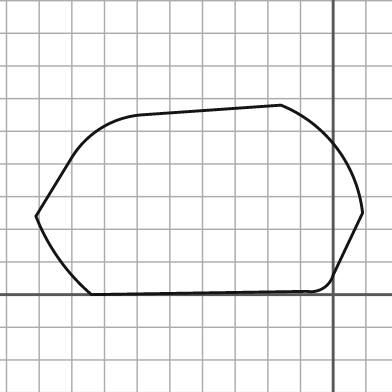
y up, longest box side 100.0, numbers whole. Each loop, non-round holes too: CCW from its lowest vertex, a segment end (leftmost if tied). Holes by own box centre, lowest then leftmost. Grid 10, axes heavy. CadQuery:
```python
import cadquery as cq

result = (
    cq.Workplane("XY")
    .moveTo(-74.0, 0.0)
    .lineTo(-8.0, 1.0)
    .threePointArc((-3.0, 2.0), (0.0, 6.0))
    .lineTo(9.0, 25.0)
    .threePointArc((1.0, 45.0), (-16.0, 58.0))
    .lineTo(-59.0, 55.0)
    .threePointArc((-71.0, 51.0), (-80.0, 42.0))
    .lineTo(-91.0, 24.0)
    .threePointArc((-84.0, 11.0), (-74.0, 0.0))
    .close()
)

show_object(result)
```